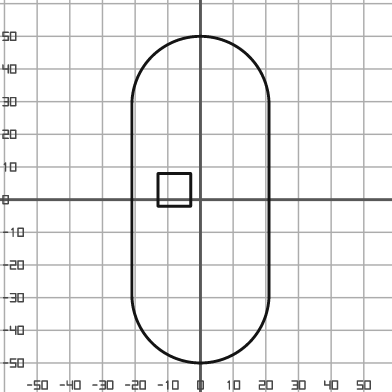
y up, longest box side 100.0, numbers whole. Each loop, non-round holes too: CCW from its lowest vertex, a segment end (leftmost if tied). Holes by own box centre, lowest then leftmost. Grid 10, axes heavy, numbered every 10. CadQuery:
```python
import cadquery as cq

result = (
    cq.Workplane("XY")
    .moveTo(-21.0, -29.0)
    .threePointArc((0.0, -50.0), (21.0, -29.0))
    .lineTo(21.0, 29.0)
    .threePointArc((0.0, 50.0), (-21.0, 29.0))
    .close()
    .moveTo(-13.0, -2.0)
    .lineTo(-3.0, -2.0)
    .lineTo(-3.0, 8.0)
    .lineTo(-13.0, 8.0)
    .close()
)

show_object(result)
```